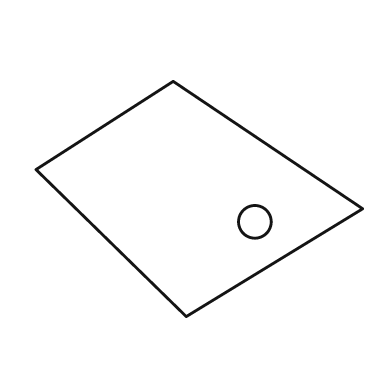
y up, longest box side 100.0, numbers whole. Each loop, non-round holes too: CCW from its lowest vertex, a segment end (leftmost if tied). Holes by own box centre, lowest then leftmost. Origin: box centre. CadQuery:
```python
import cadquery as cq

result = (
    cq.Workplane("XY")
    .moveTo(-4.0, -36.0)
    .lineTo(50.0, -3.0)
    .lineTo(-8.0, 36.0)
    .lineTo(-50.0, 9.0)
    .close()
    .moveTo(17.0, -7.0)
    .circle(5.0)
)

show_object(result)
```